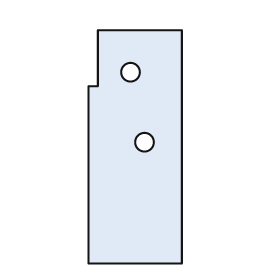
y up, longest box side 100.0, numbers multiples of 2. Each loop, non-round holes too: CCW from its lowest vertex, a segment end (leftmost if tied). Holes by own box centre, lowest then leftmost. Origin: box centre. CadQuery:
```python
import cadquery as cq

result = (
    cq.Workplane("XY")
    .moveTo(-20.0, -50.0)
    .lineTo(20.0, -50.0)
    .lineTo(20.0, 50.0)
    .lineTo(-16.0, 50.0)
    .lineTo(-16.0, 26.0)
    .lineTo(-20.0, 26.0)
    .close()
    .moveTo(4.0, 2.0)
    .circle(4.0)
    .moveTo(-2.0, 32.0)
    .circle(4.0)
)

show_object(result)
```